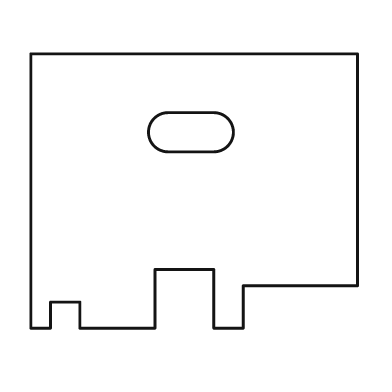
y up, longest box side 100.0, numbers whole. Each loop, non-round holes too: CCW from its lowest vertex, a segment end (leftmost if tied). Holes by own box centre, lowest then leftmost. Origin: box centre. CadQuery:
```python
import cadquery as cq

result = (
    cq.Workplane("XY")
    .moveTo(-50.0, -42.0)
    .lineTo(-44.0, -42.0)
    .lineTo(-44.0, -34.0)
    .lineTo(-35.0, -34.0)
    .lineTo(-35.0, -42.0)
    .lineTo(-12.0, -42.0)
    .lineTo(-12.0, -24.0)
    .lineTo(6.0, -24.0)
    .lineTo(6.0, -42.0)
    .lineTo(15.0, -42.0)
    .lineTo(15.0, -29.0)
    .lineTo(50.0, -29.0)
    .lineTo(50.0, 42.0)
    .lineTo(-50.0, 42.0)
    .close()
    .moveTo(-8.0, 12.0)
    .lineTo(6.0, 12.0)
    .threePointArc((12.0, 18.0), (6.0, 24.0))
    .lineTo(-8.0, 24.0)
    .threePointArc((-14.0, 18.0), (-8.0, 12.0))
    .close()
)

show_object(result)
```